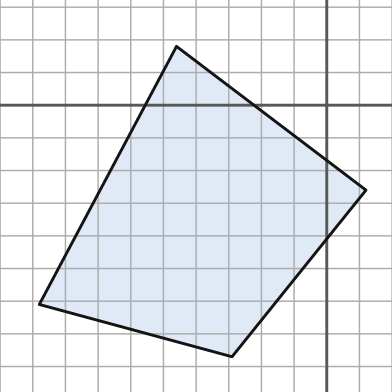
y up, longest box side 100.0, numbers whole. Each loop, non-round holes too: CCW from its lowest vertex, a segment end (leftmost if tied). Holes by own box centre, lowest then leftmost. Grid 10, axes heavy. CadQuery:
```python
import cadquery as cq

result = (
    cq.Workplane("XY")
    .moveTo(-29.0, -77.0)
    .lineTo(12.0, -26.0)
    .lineTo(-46.0, 18.0)
    .lineTo(-88.0, -61.0)
    .close()
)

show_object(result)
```